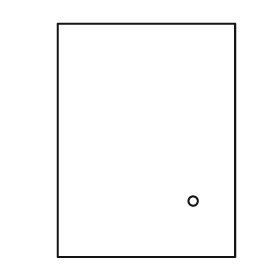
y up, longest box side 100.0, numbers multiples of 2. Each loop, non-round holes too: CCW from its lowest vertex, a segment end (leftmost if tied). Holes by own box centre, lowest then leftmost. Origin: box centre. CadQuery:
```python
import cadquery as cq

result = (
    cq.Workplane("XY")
    .moveTo(-38.0, -50.0)
    .lineTo(38.0, -50.0)
    .lineTo(38.0, 50.0)
    .lineTo(-38.0, 50.0)
    .close()
    .moveTo(20.0, -26.0)
    .circle(2.0)
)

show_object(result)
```